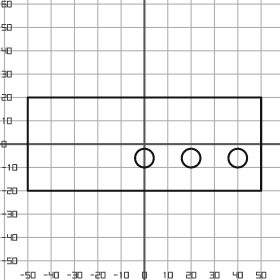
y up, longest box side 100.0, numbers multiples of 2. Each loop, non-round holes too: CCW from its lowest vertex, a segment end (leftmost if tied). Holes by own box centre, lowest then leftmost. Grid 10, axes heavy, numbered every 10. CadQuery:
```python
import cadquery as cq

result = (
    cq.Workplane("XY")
    .moveTo(-50.0, -20.0)
    .lineTo(50.0, -20.0)
    .lineTo(50.0, 20.0)
    .lineTo(-50.0, 20.0)
    .close()
    .moveTo(0.0, -6.0)
    .circle(4.0)
    .moveTo(20.0, -6.0)
    .circle(4.0)
    .moveTo(40.0, -6.0)
    .circle(4.0)
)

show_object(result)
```